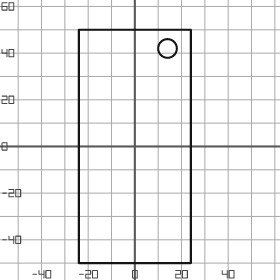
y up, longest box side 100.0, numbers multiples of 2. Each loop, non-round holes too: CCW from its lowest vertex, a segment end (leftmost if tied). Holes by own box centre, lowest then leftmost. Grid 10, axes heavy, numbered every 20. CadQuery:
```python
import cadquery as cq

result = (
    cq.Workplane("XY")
    .moveTo(-24.0, -50.0)
    .lineTo(24.0, -50.0)
    .lineTo(24.0, 50.0)
    .lineTo(-24.0, 50.0)
    .close()
    .moveTo(14.0, 42.0)
    .circle(4.0)
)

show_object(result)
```